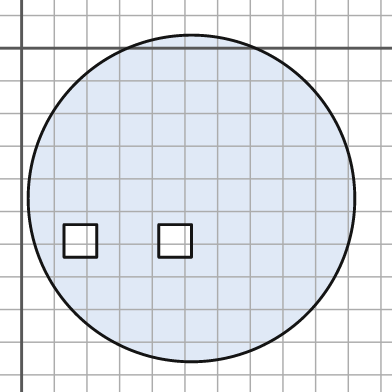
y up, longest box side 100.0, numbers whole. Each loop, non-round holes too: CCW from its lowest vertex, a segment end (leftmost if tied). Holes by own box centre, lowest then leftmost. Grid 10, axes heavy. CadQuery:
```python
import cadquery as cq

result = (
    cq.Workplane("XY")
    .moveTo(52.0, -46.0)
    .circle(50.0)
    .moveTo(13.0, -64.0)
    .lineTo(23.0, -64.0)
    .lineTo(23.0, -54.0)
    .lineTo(13.0, -54.0)
    .close()
    .moveTo(42.0, -64.0)
    .lineTo(52.0, -64.0)
    .lineTo(52.0, -54.0)
    .lineTo(42.0, -54.0)
    .close()
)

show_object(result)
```